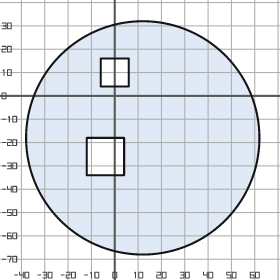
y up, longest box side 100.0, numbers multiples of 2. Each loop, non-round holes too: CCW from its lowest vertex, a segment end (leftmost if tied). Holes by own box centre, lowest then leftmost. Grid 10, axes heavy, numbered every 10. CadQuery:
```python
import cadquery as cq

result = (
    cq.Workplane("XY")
    .moveTo(12.0, -18.0)
    .circle(50.0)
    .moveTo(-12.0, -34.0)
    .lineTo(4.0, -34.0)
    .lineTo(4.0, -18.0)
    .lineTo(-12.0, -18.0)
    .close()
    .moveTo(-6.0, 4.0)
    .lineTo(6.0, 4.0)
    .lineTo(6.0, 16.0)
    .lineTo(-6.0, 16.0)
    .close()
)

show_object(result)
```